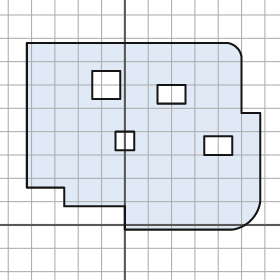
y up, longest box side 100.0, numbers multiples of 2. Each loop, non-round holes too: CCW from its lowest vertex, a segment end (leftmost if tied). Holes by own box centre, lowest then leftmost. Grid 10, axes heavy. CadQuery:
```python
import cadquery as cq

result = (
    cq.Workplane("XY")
    .moveTo(0.0, -2.0)
    .lineTo(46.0, -2.0)
    .threePointArc((54.0, 2.0), (58.0, 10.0))
    .lineTo(58.0, 48.0)
    .lineTo(50.0, 48.0)
    .lineTo(50.0, 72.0)
    .threePointArc((48.0, 76.0), (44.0, 78.0))
    .lineTo(-42.0, 78.0)
    .lineTo(-42.0, 16.0)
    .lineTo(-26.0, 16.0)
    .lineTo(-26.0, 8.0)
    .lineTo(0.0, 8.0)
    .close()
    .moveTo(34.0, 30.0)
    .lineTo(46.0, 30.0)
    .lineTo(46.0, 38.0)
    .lineTo(34.0, 38.0)
    .close()
    .moveTo(-4.0, 32.0)
    .lineTo(4.0, 32.0)
    .lineTo(4.0, 40.0)
    .lineTo(-4.0, 40.0)
    .close()
    .moveTo(14.0, 52.0)
    .lineTo(26.0, 52.0)
    .lineTo(26.0, 60.0)
    .lineTo(14.0, 60.0)
    .close()
    .moveTo(-14.0, 54.0)
    .lineTo(-2.0, 54.0)
    .lineTo(-2.0, 66.0)
    .lineTo(-14.0, 66.0)
    .close()
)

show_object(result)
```